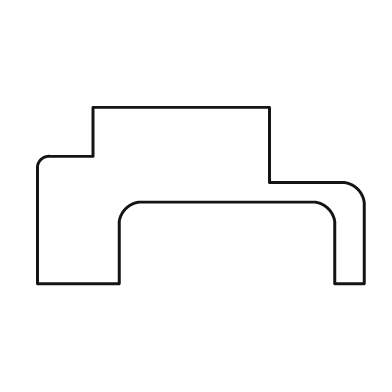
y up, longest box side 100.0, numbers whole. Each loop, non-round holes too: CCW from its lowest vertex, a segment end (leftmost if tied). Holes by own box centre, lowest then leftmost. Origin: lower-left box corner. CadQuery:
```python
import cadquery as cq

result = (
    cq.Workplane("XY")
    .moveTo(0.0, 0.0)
    .lineTo(25.0, 0.0)
    .lineTo(25.0, 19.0)
    .threePointArc((27.0, 23.0), (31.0, 25.0))
    .lineTo(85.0, 25.0)
    .threePointArc((89.0, 23.0), (91.0, 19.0))
    .lineTo(91.0, 0.0)
    .lineTo(100.0, 0.0)
    .lineTo(100.0, 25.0)
    .threePointArc((98.0, 29.0), (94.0, 31.0))
    .lineTo(71.0, 31.0)
    .lineTo(71.0, 54.0)
    .lineTo(17.0, 54.0)
    .lineTo(17.0, 39.0)
    .lineTo(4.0, 39.0)
    .threePointArc((1.0, 38.0), (0.0, 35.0))
    .close()
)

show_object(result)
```